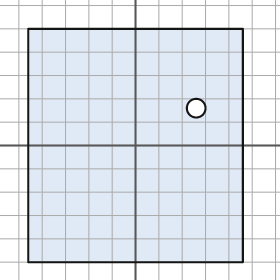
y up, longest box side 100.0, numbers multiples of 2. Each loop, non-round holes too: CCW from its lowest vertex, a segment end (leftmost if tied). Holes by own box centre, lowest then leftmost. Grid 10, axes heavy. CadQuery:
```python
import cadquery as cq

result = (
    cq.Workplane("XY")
    .moveTo(-46.0, -50.0)
    .lineTo(46.0, -50.0)
    .lineTo(46.0, 50.0)
    .lineTo(-46.0, 50.0)
    .close()
    .moveTo(26.0, 16.0)
    .circle(4.0)
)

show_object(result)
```